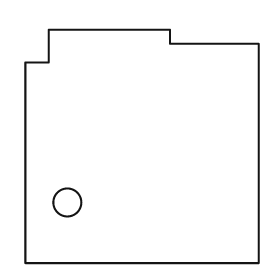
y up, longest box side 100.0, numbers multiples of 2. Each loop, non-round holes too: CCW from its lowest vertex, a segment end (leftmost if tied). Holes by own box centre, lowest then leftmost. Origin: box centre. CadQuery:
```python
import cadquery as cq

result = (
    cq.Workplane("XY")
    .moveTo(-50.0, -50.0)
    .lineTo(50.0, -50.0)
    .lineTo(50.0, 44.0)
    .lineTo(12.0, 44.0)
    .lineTo(12.0, 50.0)
    .lineTo(-40.0, 50.0)
    .lineTo(-40.0, 36.0)
    .lineTo(-50.0, 36.0)
    .close()
    .moveTo(-32.0, -24.0)
    .circle(6.0)
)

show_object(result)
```